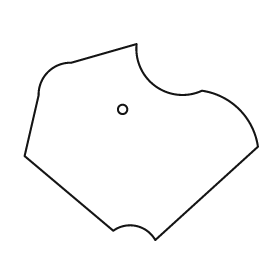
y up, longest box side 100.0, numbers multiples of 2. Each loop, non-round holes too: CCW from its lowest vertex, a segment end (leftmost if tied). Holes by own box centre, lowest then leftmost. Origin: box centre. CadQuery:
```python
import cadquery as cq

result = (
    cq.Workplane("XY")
    .moveTo(6.0, -42.0)
    .lineTo(50.0, -2.0)
    .threePointArc((42.0, 14.0), (26.0, 22.0))
    .threePointArc((6.0, 24.0), (-2.0, 42.0))
    .lineTo(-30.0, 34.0)
    .threePointArc((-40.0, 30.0), (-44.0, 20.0))
    .lineTo(-50.0, -6.0)
    .lineTo(-12.0, -38.0)
    .threePointArc((-2.0, -36.0), (6.0, -42.0))
    .close()
    .moveTo(-8.0, 14.0)
    .circle(2.0)
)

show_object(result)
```